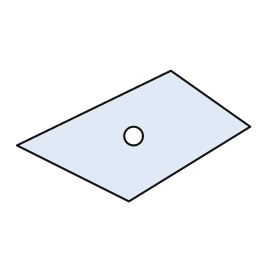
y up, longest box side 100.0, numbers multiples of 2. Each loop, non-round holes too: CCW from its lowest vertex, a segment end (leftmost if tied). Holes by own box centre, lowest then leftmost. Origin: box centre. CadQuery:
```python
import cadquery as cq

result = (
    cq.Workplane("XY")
    .moveTo(-2.0, -28.0)
    .lineTo(50.0, 4.0)
    .lineTo(16.0, 28.0)
    .lineTo(-50.0, -4.0)
    .close()
    .moveTo(0.0, 0.0)
    .circle(4.0)
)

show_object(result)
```